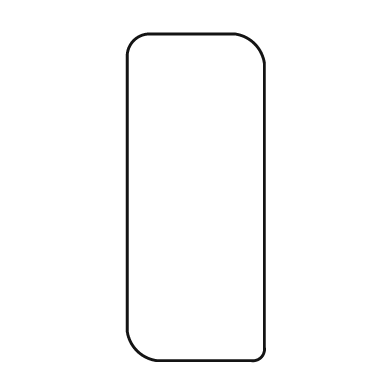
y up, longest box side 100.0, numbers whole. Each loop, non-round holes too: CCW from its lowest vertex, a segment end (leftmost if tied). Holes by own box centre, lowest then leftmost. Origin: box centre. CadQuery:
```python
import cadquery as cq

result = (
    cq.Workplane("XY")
    .moveTo(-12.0, -50.0)
    .lineTo(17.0, -50.0)
    .threePointArc((20.0, -49.0), (21.0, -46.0))
    .lineTo(21.0, 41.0)
    .threePointArc((18.0, 47.0), (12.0, 50.0))
    .lineTo(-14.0, 50.0)
    .threePointArc((-19.0, 48.0), (-21.0, 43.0))
    .lineTo(-21.0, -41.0)
    .threePointArc((-18.0, -47.0), (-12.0, -50.0))
    .close()
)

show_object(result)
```